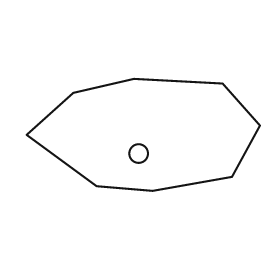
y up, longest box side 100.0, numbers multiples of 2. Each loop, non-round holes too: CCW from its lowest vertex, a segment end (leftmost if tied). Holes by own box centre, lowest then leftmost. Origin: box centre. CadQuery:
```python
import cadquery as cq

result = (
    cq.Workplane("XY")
    .moveTo(4.0, -24.0)
    .lineTo(38.0, -18.0)
    .lineTo(50.0, 4.0)
    .lineTo(34.0, 22.0)
    .lineTo(-4.0, 24.0)
    .lineTo(-30.0, 18.0)
    .lineTo(-50.0, 0.0)
    .lineTo(-20.0, -22.0)
    .close()
    .moveTo(-2.0, -8.0)
    .circle(4.0)
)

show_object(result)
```